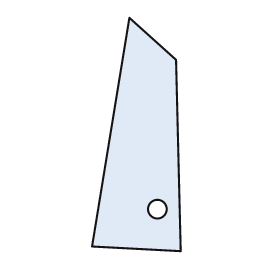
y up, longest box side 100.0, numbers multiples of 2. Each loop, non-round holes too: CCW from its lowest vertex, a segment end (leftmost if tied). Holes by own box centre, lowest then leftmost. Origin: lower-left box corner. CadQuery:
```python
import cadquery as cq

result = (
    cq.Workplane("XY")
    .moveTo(38.0, 0.0)
    .lineTo(36.0, 82.0)
    .lineTo(16.0, 100.0)
    .lineTo(0.0, 2.0)
    .close()
    .moveTo(28.0, 18.0)
    .circle(4.0)
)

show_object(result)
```